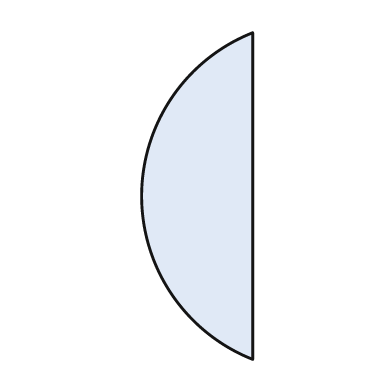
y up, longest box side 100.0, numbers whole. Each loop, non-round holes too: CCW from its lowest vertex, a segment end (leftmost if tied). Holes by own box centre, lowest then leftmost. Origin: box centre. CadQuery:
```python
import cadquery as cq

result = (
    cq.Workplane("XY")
    .moveTo(17.0, -50.0)
    .lineTo(17.0, 50.0)
    .threePointArc((-17.0, 0.0), (17.0, -50.0))
    .close()
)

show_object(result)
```